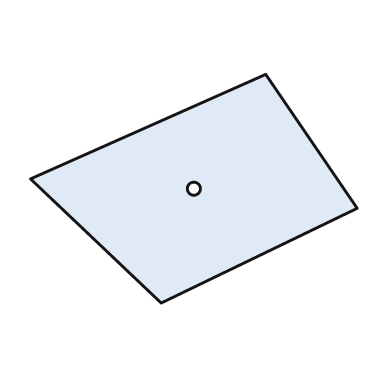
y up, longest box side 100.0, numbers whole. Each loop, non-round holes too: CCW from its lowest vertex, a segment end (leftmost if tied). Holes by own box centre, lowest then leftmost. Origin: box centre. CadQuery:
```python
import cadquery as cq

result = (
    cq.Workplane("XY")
    .moveTo(-10.0, -35.0)
    .lineTo(50.0, -6.0)
    .lineTo(22.0, 35.0)
    .lineTo(-50.0, 3.0)
    .close()
    .moveTo(0.0, 0.0)
    .circle(2.0)
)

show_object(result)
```